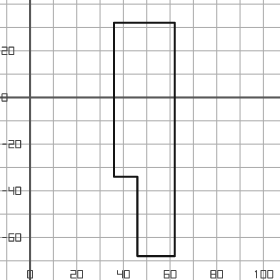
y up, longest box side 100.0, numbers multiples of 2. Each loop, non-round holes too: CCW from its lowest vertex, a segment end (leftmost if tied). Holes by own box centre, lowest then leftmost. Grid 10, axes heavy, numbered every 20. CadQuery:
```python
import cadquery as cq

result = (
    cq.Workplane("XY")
    .moveTo(46.0, -68.0)
    .lineTo(62.0, -68.0)
    .lineTo(62.0, 32.0)
    .lineTo(36.0, 32.0)
    .lineTo(36.0, -34.0)
    .lineTo(46.0, -34.0)
    .close()
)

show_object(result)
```